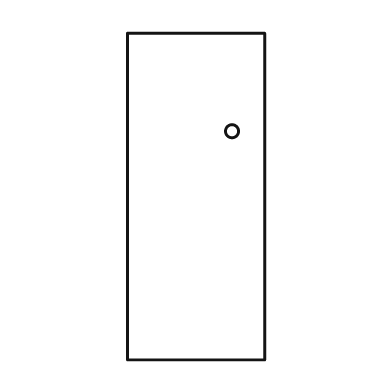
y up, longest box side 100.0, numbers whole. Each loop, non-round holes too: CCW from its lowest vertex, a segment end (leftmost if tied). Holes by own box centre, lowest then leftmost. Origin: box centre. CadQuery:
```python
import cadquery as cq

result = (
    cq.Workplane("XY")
    .moveTo(-21.0, -50.0)
    .lineTo(21.0, -50.0)
    .lineTo(21.0, 50.0)
    .lineTo(-21.0, 50.0)
    .close()
    .moveTo(11.0, 20.0)
    .circle(2.0)
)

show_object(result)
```